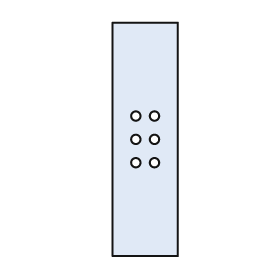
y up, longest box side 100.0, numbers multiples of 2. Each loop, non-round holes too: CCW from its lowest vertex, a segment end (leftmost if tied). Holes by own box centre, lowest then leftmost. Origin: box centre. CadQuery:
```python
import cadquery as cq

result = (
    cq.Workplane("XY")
    .moveTo(-14.0, -50.0)
    .lineTo(14.0, -50.0)
    .lineTo(14.0, 50.0)
    .lineTo(-14.0, 50.0)
    .close()
    .moveTo(-4.0, -10.0)
    .circle(2.0)
    .moveTo(4.0, -10.0)
    .circle(2.0)
    .moveTo(-4.0, 0.0)
    .circle(2.0)
    .moveTo(4.0, 0.0)
    .circle(2.0)
    .moveTo(-4.0, 10.0)
    .circle(2.0)
    .moveTo(4.0, 10.0)
    .circle(2.0)
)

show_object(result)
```